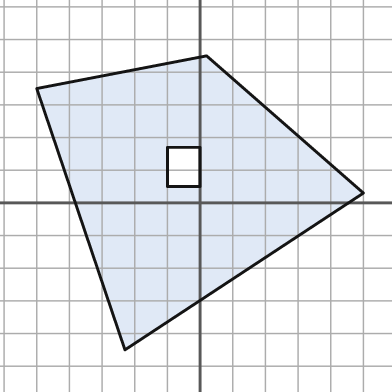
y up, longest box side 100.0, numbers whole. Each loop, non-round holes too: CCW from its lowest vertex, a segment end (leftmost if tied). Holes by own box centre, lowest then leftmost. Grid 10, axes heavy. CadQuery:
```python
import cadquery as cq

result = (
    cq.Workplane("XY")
    .moveTo(-23.0, -45.0)
    .lineTo(50.0, 3.0)
    .lineTo(2.0, 45.0)
    .lineTo(-50.0, 35.0)
    .close()
    .moveTo(-10.0, 5.0)
    .lineTo(0.0, 5.0)
    .lineTo(0.0, 17.0)
    .lineTo(-10.0, 17.0)
    .close()
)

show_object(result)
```